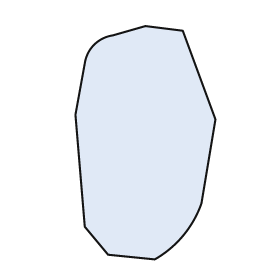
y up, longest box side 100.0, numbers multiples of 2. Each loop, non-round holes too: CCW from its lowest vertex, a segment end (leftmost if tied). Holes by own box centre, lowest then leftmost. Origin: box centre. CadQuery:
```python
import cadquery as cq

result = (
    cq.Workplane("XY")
    .moveTo(4.0, -50.0)
    .threePointArc((16.0, -40.0), (24.0, -26.0))
    .lineTo(30.0, 10.0)
    .lineTo(16.0, 48.0)
    .lineTo(0.0, 50.0)
    .lineTo(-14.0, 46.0)
    .threePointArc((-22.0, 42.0), (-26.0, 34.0))
    .lineTo(-30.0, 12.0)
    .lineTo(-26.0, -36.0)
    .lineTo(-16.0, -48.0)
    .close()
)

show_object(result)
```